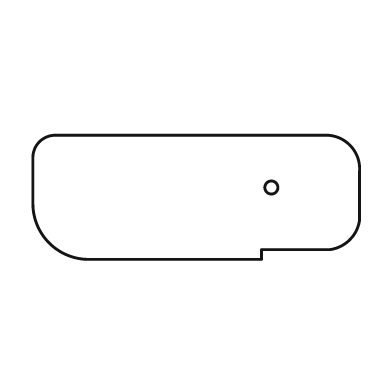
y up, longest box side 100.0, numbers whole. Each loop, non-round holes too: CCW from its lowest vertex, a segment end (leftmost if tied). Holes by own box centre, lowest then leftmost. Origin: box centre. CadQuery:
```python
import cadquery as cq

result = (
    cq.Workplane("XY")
    .moveTo(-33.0, -19.0)
    .lineTo(20.0, -19.0)
    .lineTo(20.0, -16.0)
    .lineTo(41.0, -16.0)
    .threePointArc((47.0, -13.0), (50.0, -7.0))
    .lineTo(50.0, 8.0)
    .threePointArc((47.0, 16.0), (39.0, 19.0))
    .lineTo(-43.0, 19.0)
    .threePointArc((-48.0, 17.0), (-50.0, 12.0))
    .lineTo(-50.0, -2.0)
    .threePointArc((-45.0, -14.0), (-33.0, -19.0))
    .close()
    .moveTo(23.0, 3.0)
    .circle(2.0)
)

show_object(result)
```